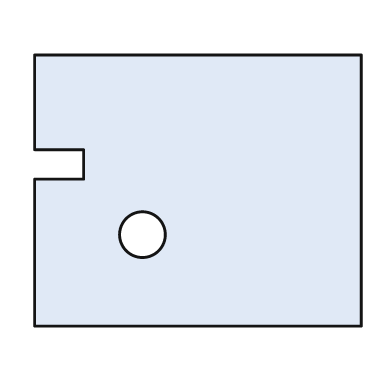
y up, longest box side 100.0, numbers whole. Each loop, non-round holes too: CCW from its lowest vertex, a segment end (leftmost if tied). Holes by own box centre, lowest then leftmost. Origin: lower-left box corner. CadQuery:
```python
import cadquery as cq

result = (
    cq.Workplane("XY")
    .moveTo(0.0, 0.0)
    .lineTo(100.0, 0.0)
    .lineTo(100.0, 83.0)
    .lineTo(0.0, 83.0)
    .lineTo(0.0, 54.0)
    .lineTo(15.0, 54.0)
    .lineTo(15.0, 45.0)
    .lineTo(0.0, 45.0)
    .close()
    .moveTo(33.0, 28.0)
    .circle(7.0)
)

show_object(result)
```